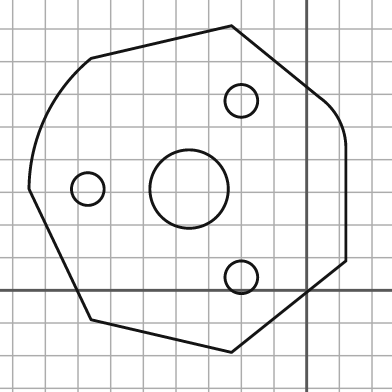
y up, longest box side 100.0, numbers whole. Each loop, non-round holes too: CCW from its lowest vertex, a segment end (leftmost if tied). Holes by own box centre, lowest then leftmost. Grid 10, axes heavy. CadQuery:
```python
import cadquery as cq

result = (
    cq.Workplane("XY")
    .moveTo(-23.0, -19.0)
    .lineTo(12.0, 9.0)
    .lineTo(12.0, 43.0)
    .threePointArc((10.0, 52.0), (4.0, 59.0))
    .lineTo(-23.0, 81.0)
    .lineTo(-66.0, 71.0)
    .threePointArc((-80.0, 53.0), (-85.0, 31.0))
    .lineTo(-66.0, -9.0)
    .close()
    .moveTo(-20.0, 4.0)
    .circle(5.0)
    .moveTo(-67.0, 31.0)
    .circle(5.0)
    .moveTo(-36.0, 31.0)
    .circle(12.0)
    .moveTo(-20.0, 58.0)
    .circle(5.0)
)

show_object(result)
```